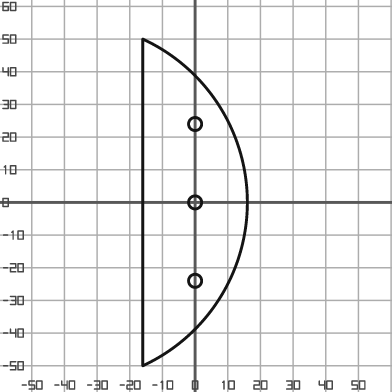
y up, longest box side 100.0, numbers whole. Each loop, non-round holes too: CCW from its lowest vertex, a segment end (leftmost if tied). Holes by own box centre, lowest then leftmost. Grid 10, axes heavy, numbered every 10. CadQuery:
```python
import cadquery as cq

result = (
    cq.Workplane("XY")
    .moveTo(-16.0, -50.0)
    .threePointArc((16.0, 0.0), (-16.0, 50.0))
    .close()
    .moveTo(0.0, -24.0)
    .circle(2.0)
    .moveTo(0.0, 0.0)
    .circle(2.0)
    .moveTo(0.0, 24.0)
    .circle(2.0)
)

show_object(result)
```